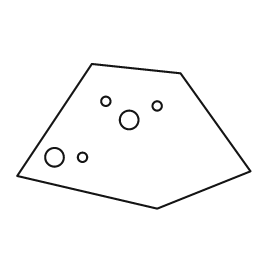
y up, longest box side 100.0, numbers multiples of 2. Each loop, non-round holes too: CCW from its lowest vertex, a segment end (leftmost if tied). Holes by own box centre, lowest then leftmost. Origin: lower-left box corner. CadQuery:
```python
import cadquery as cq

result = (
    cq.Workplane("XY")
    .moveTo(60.0, 0.0)
    .lineTo(100.0, 16.0)
    .lineTo(70.0, 58.0)
    .lineTo(32.0, 62.0)
    .lineTo(0.0, 14.0)
    .close()
    .moveTo(16.0, 22.0)
    .circle(4.0)
    .moveTo(28.0, 22.0)
    .circle(2.0)
    .moveTo(48.0, 38.0)
    .circle(4.0)
    .moveTo(60.0, 44.0)
    .circle(2.0)
    .moveTo(38.0, 46.0)
    .circle(2.0)
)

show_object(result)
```